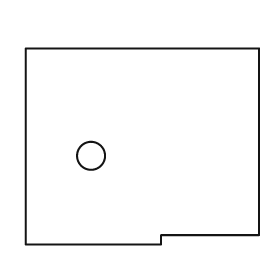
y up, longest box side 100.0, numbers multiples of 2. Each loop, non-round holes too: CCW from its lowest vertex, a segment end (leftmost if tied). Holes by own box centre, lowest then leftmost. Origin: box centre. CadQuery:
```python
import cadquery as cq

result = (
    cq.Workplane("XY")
    .moveTo(-50.0, -42.0)
    .lineTo(8.0, -42.0)
    .lineTo(8.0, -38.0)
    .lineTo(50.0, -38.0)
    .lineTo(50.0, 42.0)
    .lineTo(-50.0, 42.0)
    .close()
    .moveTo(-22.0, -4.0)
    .circle(6.0)
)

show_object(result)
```